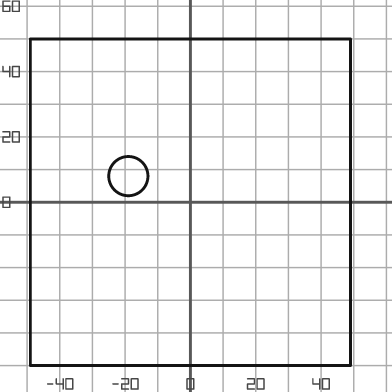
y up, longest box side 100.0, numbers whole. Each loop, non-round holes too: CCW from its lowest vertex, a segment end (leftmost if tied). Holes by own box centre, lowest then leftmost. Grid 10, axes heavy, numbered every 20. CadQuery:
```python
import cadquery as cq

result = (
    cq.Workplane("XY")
    .moveTo(-49.0, -50.0)
    .lineTo(49.0, -50.0)
    .lineTo(49.0, 50.0)
    .lineTo(-49.0, 50.0)
    .close()
    .moveTo(-19.0, 8.0)
    .circle(6.0)
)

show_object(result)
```